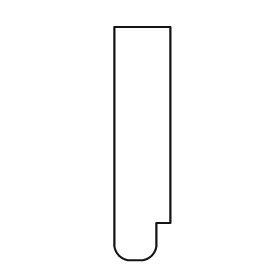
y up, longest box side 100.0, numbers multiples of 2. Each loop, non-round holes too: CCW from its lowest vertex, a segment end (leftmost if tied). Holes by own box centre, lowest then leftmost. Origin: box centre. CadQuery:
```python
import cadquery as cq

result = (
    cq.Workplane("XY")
    .moveTo(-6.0, -50.0)
    .lineTo(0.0, -50.0)
    .threePointArc((4.0, -48.0), (6.0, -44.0))
    .lineTo(6.0, -34.0)
    .lineTo(12.0, -34.0)
    .lineTo(12.0, 50.0)
    .lineTo(-12.0, 50.0)
    .lineTo(-12.0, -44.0)
    .threePointArc((-10.0, -48.0), (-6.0, -50.0))
    .close()
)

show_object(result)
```